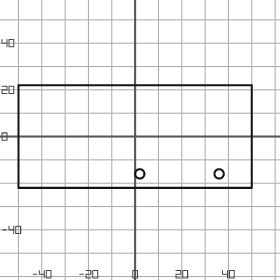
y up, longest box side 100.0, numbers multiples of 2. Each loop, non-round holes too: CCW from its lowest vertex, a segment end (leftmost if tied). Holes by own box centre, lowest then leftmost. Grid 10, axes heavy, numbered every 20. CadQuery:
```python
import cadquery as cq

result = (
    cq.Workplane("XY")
    .moveTo(-50.0, -22.0)
    .lineTo(50.0, -22.0)
    .lineTo(50.0, 22.0)
    .lineTo(-50.0, 22.0)
    .close()
    .moveTo(2.0, -16.0)
    .circle(2.0)
    .moveTo(36.0, -16.0)
    .circle(2.0)
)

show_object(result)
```